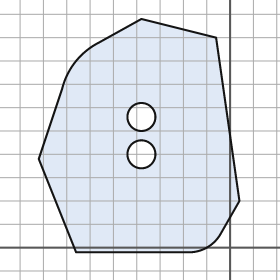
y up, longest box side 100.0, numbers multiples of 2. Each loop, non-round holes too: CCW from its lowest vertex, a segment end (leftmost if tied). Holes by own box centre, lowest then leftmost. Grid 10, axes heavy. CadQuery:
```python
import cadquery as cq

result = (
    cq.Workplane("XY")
    .moveTo(-66.0, -2.0)
    .lineTo(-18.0, -2.0)
    .threePointArc((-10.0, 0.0), (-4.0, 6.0))
    .lineTo(4.0, 20.0)
    .lineTo(-6.0, 90.0)
    .lineTo(-38.0, 98.0)
    .lineTo(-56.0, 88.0)
    .threePointArc((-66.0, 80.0), (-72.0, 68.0))
    .lineTo(-82.0, 38.0)
    .close()
    .moveTo(-38.0, 40.0)
    .circle(6.0)
    .moveTo(-38.0, 56.0)
    .circle(6.0)
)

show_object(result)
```